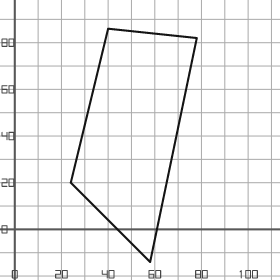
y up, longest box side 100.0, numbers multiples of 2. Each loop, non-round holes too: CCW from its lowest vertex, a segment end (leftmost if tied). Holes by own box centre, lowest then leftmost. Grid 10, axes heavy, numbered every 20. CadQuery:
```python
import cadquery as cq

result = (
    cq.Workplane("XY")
    .moveTo(58.0, -14.0)
    .lineTo(78.0, 82.0)
    .lineTo(40.0, 86.0)
    .lineTo(24.0, 20.0)
    .close()
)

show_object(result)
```